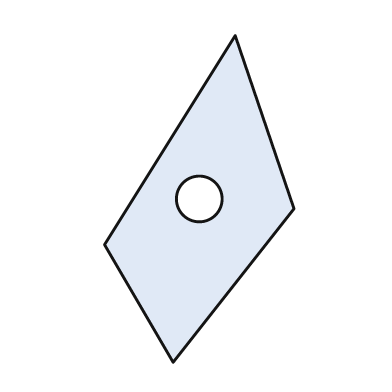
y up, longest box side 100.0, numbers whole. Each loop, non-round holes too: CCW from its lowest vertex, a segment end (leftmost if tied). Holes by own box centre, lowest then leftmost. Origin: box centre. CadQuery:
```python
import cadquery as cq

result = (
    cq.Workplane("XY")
    .moveTo(-8.0, -50.0)
    .lineTo(29.0, -3.0)
    .lineTo(11.0, 50.0)
    .lineTo(-29.0, -14.0)
    .close()
    .moveTo(0.0, 0.0)
    .circle(7.0)
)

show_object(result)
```